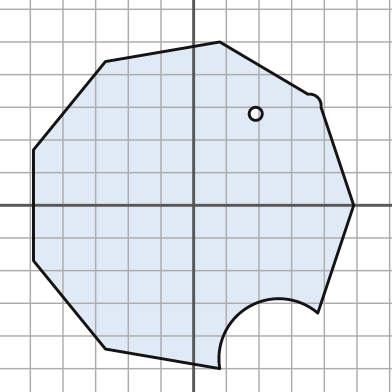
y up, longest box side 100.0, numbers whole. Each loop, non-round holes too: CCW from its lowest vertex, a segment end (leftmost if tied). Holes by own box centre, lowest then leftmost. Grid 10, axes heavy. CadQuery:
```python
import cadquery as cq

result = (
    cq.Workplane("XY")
    .moveTo(8.0, -50.0)
    .threePointArc((17.0, -31.0), (38.0, -33.0))
    .lineTo(49.0, 0.0)
    .lineTo(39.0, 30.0)
    .threePointArc((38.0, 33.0), (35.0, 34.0))
    .lineTo(8.0, 50.0)
    .lineTo(-27.0, 44.0)
    .lineTo(-49.0, 17.0)
    .lineTo(-49.0, -17.0)
    .lineTo(-27.0, -44.0)
    .close()
    .moveTo(19.0, 28.0)
    .circle(2.0)
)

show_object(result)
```